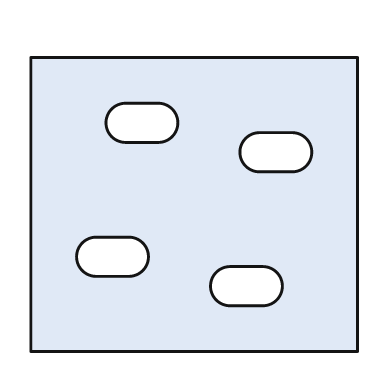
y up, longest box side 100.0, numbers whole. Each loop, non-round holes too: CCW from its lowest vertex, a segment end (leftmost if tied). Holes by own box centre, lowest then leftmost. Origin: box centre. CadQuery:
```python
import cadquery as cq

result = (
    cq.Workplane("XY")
    .moveTo(-50.0, -45.0)
    .lineTo(50.0, -45.0)
    .lineTo(50.0, 45.0)
    .lineTo(-50.0, 45.0)
    .close()
    .moveTo(11.0, -31.0)
    .lineTo(21.0, -31.0)
    .threePointArc((27.0, -25.0), (21.0, -19.0))
    .lineTo(11.0, -19.0)
    .threePointArc((5.0, -25.0), (11.0, -31.0))
    .close()
    .moveTo(-30.0, -22.0)
    .lineTo(-20.0, -22.0)
    .threePointArc((-14.0, -16.0), (-20.0, -10.0))
    .lineTo(-30.0, -10.0)
    .threePointArc((-36.0, -16.0), (-30.0, -22.0))
    .close()
    .moveTo(20.0, 10.0)
    .lineTo(30.0, 10.0)
    .threePointArc((36.0, 16.0), (30.0, 22.0))
    .lineTo(20.0, 22.0)
    .threePointArc((14.0, 16.0), (20.0, 10.0))
    .close()
    .moveTo(-21.0, 19.0)
    .lineTo(-11.0, 19.0)
    .threePointArc((-5.0, 25.0), (-11.0, 31.0))
    .lineTo(-21.0, 31.0)
    .threePointArc((-27.0, 25.0), (-21.0, 19.0))
    .close()
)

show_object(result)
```